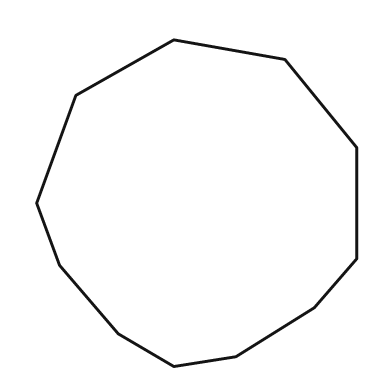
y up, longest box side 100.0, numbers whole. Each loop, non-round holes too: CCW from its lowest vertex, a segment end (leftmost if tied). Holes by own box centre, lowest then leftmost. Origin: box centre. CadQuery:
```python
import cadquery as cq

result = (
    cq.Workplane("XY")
    .moveTo(-7.0, -50.0)
    .lineTo(12.0, -47.0)
    .lineTo(36.0, -32.0)
    .lineTo(49.0, -17.0)
    .lineTo(49.0, 17.0)
    .lineTo(27.0, 44.0)
    .lineTo(-7.0, 50.0)
    .lineTo(-37.0, 33.0)
    .lineTo(-49.0, 0.0)
    .lineTo(-42.0, -19.0)
    .lineTo(-24.0, -40.0)
    .close()
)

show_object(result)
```